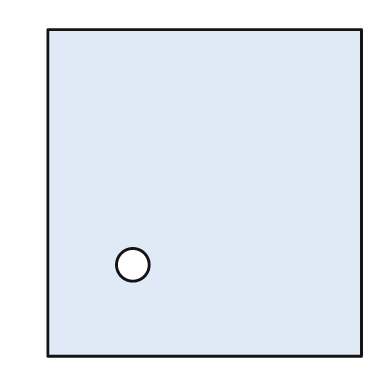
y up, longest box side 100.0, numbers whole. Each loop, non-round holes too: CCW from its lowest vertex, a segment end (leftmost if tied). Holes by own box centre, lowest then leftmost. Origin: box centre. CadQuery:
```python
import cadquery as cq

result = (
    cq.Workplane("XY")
    .moveTo(-48.0, -50.0)
    .lineTo(48.0, -50.0)
    .lineTo(48.0, 50.0)
    .lineTo(-48.0, 50.0)
    .close()
    .moveTo(-22.0, -22.0)
    .circle(5.0)
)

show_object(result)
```